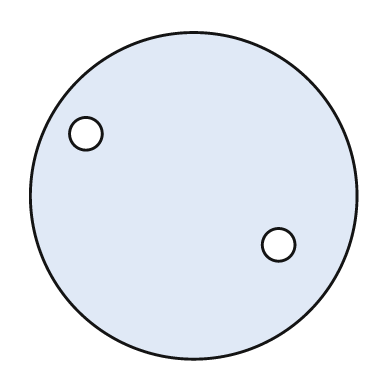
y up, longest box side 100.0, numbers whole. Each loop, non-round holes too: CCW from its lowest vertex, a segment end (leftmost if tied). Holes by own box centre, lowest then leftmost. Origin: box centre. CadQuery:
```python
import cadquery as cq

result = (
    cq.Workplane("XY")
    .moveTo(0.0, 0.0)
    .circle(50.0)
    .moveTo(26.0, -15.0)
    .circle(5.0)
    .moveTo(-33.0, 19.0)
    .circle(5.0)
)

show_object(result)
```